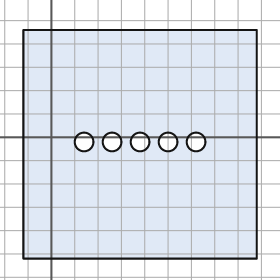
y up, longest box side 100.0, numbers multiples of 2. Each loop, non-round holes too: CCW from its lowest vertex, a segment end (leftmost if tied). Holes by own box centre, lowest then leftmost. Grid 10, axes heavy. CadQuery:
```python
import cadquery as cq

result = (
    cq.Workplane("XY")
    .moveTo(-12.0, -52.0)
    .lineTo(88.0, -52.0)
    .lineTo(88.0, 46.0)
    .lineTo(-12.0, 46.0)
    .close()
    .moveTo(14.0, -2.0)
    .circle(4.0)
    .moveTo(26.0, -2.0)
    .circle(4.0)
    .moveTo(38.0, -2.0)
    .circle(4.0)
    .moveTo(50.0, -2.0)
    .circle(4.0)
    .moveTo(62.0, -2.0)
    .circle(4.0)
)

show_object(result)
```